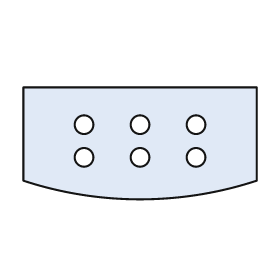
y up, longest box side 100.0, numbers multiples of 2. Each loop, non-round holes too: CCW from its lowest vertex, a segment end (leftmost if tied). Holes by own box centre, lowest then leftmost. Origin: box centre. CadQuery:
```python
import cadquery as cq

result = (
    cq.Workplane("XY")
    .moveTo(-50.0, -16.0)
    .threePointArc((0.0, -24.0), (50.0, -16.0))
    .lineTo(50.0, 24.0)
    .lineTo(-50.0, 24.0)
    .close()
    .moveTo(-24.0, -6.0)
    .circle(4.0)
    .moveTo(0.0, -6.0)
    .circle(4.0)
    .moveTo(24.0, -6.0)
    .circle(4.0)
    .moveTo(-24.0, 8.0)
    .circle(4.0)
    .moveTo(0.0, 8.0)
    .circle(4.0)
    .moveTo(24.0, 8.0)
    .circle(4.0)
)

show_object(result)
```